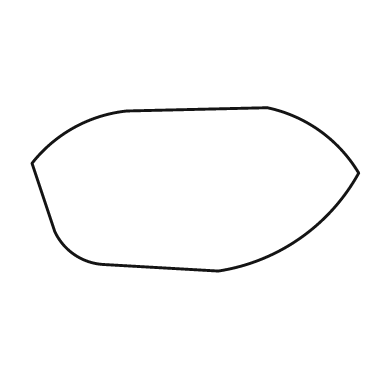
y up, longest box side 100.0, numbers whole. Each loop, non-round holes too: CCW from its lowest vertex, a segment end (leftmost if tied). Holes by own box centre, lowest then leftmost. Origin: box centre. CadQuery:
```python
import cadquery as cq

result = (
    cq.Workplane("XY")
    .moveTo(7.0, -25.0)
    .threePointArc((32.0, -15.0), (50.0, 5.0))
    .threePointArc((38.0, 18.0), (22.0, 25.0))
    .lineTo(-21.0, 24.0)
    .threePointArc((-37.0, 19.0), (-50.0, 8.0))
    .lineTo(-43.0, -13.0)
    .threePointArc((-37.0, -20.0), (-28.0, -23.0))
    .close()
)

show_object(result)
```